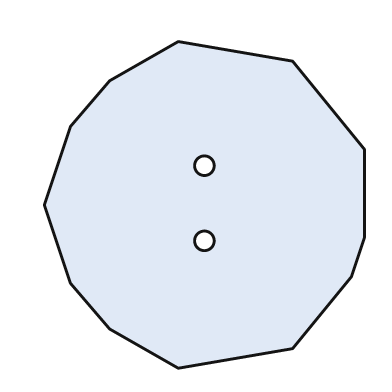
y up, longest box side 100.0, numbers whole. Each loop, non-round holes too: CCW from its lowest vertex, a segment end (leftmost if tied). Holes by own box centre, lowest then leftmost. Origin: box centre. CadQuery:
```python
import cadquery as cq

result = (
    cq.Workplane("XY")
    .moveTo(-8.0, -50.0)
    .lineTo(27.0, -44.0)
    .lineTo(45.0, -22.0)
    .lineTo(49.0, -10.0)
    .lineTo(49.0, 17.0)
    .lineTo(27.0, 44.0)
    .lineTo(-8.0, 50.0)
    .lineTo(-29.0, 38.0)
    .lineTo(-41.0, 24.0)
    .lineTo(-49.0, 0.0)
    .lineTo(-41.0, -24.0)
    .lineTo(-29.0, -38.0)
    .close()
    .moveTo(0.0, -11.0)
    .circle(3.0)
    .moveTo(0.0, 12.0)
    .circle(3.0)
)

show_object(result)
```